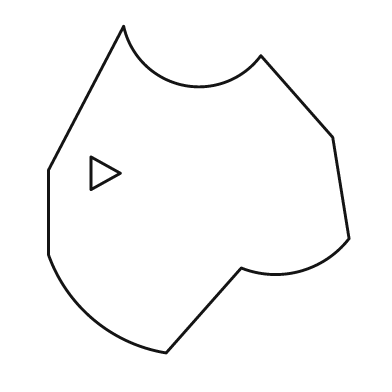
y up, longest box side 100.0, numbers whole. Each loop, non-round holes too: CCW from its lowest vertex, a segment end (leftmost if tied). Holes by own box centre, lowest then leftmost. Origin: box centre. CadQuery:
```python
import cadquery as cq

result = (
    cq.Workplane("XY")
    .moveTo(-10.0, -50.0)
    .lineTo(13.0, -24.0)
    .threePointArc((31.0, -25.0), (46.0, -15.0))
    .lineTo(41.0, 16.0)
    .lineTo(19.0, 41.0)
    .threePointArc((-5.0, 32.0), (-23.0, 50.0))
    .lineTo(-46.0, 6.0)
    .lineTo(-46.0, -20.0)
    .threePointArc((-32.0, -40.0), (-10.0, -50.0))
    .close()
    .moveTo(-33.0, 0.0)
    .lineTo(-24.0, 5.0)
    .lineTo(-33.0, 10.0)
    .close()
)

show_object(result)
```